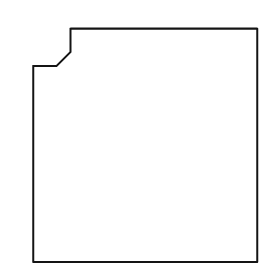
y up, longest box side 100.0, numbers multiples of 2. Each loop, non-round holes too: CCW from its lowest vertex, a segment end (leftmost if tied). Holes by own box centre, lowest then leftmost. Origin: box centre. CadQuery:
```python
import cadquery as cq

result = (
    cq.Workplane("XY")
    .moveTo(-48.0, -50.0)
    .lineTo(48.0, -50.0)
    .lineTo(48.0, 50.0)
    .lineTo(-32.0, 50.0)
    .lineTo(-32.0, 40.0)
    .lineTo(-38.0, 34.0)
    .lineTo(-48.0, 34.0)
    .close()
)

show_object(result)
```